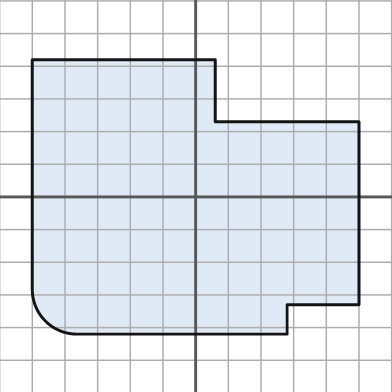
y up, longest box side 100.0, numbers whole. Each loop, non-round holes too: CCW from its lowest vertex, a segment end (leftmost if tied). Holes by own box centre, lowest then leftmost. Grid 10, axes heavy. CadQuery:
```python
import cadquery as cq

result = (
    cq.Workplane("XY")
    .moveTo(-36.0, -42.0)
    .lineTo(28.0, -42.0)
    .lineTo(28.0, -33.0)
    .lineTo(50.0, -33.0)
    .lineTo(50.0, 23.0)
    .lineTo(6.0, 23.0)
    .lineTo(6.0, 42.0)
    .lineTo(-50.0, 42.0)
    .lineTo(-50.0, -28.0)
    .threePointArc((-46.0, -38.0), (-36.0, -42.0))
    .close()
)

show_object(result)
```